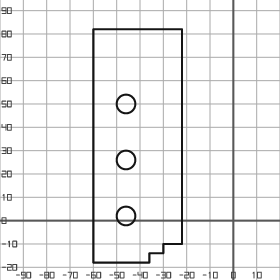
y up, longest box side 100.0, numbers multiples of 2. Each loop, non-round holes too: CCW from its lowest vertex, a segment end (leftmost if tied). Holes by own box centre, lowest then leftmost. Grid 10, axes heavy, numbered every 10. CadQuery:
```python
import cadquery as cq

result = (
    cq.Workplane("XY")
    .moveTo(-60.0, -18.0)
    .lineTo(-36.0, -18.0)
    .lineTo(-36.0, -14.0)
    .lineTo(-30.0, -14.0)
    .lineTo(-30.0, -10.0)
    .lineTo(-22.0, -10.0)
    .lineTo(-22.0, 82.0)
    .lineTo(-60.0, 82.0)
    .close()
    .moveTo(-46.0, 2.0)
    .circle(4.0)
    .moveTo(-46.0, 26.0)
    .circle(4.0)
    .moveTo(-46.0, 50.0)
    .circle(4.0)
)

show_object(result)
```